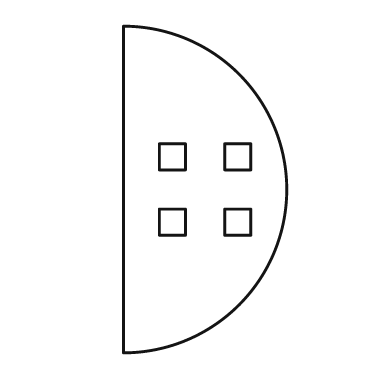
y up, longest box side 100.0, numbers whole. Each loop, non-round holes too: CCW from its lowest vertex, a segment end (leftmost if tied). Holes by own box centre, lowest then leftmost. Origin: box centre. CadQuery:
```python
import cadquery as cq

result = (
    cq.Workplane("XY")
    .moveTo(-25.0, -50.0)
    .threePointArc((25.0, 0.0), (-25.0, 50.0))
    .close()
    .moveTo(-14.0, -14.0)
    .lineTo(-6.0, -14.0)
    .lineTo(-6.0, -6.0)
    .lineTo(-14.0, -6.0)
    .close()
    .moveTo(6.0, -14.0)
    .lineTo(14.0, -14.0)
    .lineTo(14.0, -6.0)
    .lineTo(6.0, -6.0)
    .close()
    .moveTo(-14.0, 6.0)
    .lineTo(-6.0, 6.0)
    .lineTo(-6.0, 14.0)
    .lineTo(-14.0, 14.0)
    .close()
    .moveTo(6.0, 6.0)
    .lineTo(14.0, 6.0)
    .lineTo(14.0, 14.0)
    .lineTo(6.0, 14.0)
    .close()
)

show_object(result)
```